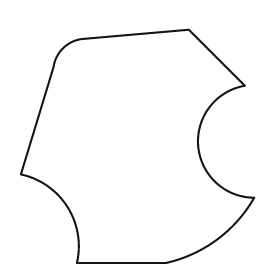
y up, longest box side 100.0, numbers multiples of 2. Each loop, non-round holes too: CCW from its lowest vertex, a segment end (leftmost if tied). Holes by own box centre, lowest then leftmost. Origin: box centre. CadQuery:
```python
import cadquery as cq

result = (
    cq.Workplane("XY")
    .moveTo(-26.0, -50.0)
    .lineTo(12.0, -50.0)
    .threePointArc((34.0, -40.0), (50.0, -22.0))
    .threePointArc((26.0, 0.0), (46.0, 26.0))
    .lineTo(22.0, 50.0)
    .lineTo(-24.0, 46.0)
    .threePointArc((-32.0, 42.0), (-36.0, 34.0))
    .lineTo(-50.0, -12.0)
    .threePointArc((-30.0, -26.0), (-26.0, -50.0))
    .close()
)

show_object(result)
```